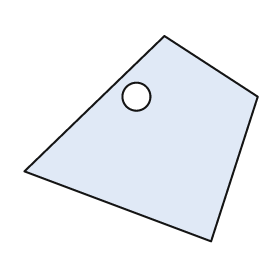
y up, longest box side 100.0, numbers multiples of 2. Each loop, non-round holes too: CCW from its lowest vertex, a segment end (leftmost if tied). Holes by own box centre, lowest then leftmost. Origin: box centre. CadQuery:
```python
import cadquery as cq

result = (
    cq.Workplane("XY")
    .moveTo(30.0, -44.0)
    .lineTo(50.0, 18.0)
    .lineTo(10.0, 44.0)
    .lineTo(-50.0, -14.0)
    .close()
    .moveTo(-2.0, 18.0)
    .circle(6.0)
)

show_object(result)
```